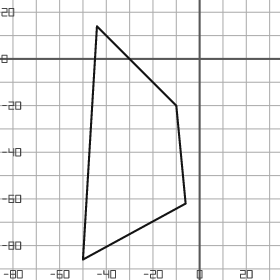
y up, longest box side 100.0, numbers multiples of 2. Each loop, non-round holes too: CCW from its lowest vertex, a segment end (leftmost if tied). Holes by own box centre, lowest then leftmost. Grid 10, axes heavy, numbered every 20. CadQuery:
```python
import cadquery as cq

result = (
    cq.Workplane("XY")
    .moveTo(-50.0, -86.0)
    .lineTo(-6.0, -62.0)
    .lineTo(-10.0, -20.0)
    .lineTo(-44.0, 14.0)
    .close()
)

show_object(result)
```